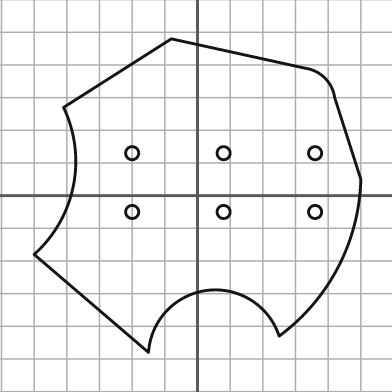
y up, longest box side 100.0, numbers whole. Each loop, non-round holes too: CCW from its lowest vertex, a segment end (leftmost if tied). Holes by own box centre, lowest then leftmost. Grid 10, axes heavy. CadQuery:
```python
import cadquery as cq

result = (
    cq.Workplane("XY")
    .moveTo(-15.0, -48.0)
    .threePointArc((3.0, -29.0), (25.0, -43.0))
    .threePointArc((43.0, -22.0), (50.0, 5.0))
    .lineTo(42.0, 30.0)
    .threePointArc((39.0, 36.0), (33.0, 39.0))
    .lineTo(-8.0, 48.0)
    .lineTo(-41.0, 27.0)
    .threePointArc((-38.0, 3.0), (-50.0, -18.0))
    .close()
    .moveTo(-20.0, -5.0)
    .circle(2.0)
    .moveTo(8.0, -5.0)
    .circle(2.0)
    .moveTo(36.0, -5.0)
    .circle(2.0)
    .moveTo(-20.0, 13.0)
    .circle(2.0)
    .moveTo(8.0, 13.0)
    .circle(2.0)
    .moveTo(36.0, 13.0)
    .circle(2.0)
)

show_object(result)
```